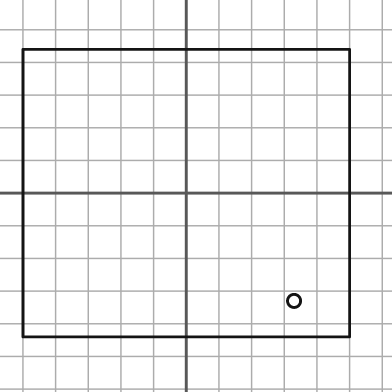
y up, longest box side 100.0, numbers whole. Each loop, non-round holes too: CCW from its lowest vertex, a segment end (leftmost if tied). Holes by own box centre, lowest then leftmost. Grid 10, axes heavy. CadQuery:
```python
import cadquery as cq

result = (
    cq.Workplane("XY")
    .moveTo(-50.0, -44.0)
    .lineTo(50.0, -44.0)
    .lineTo(50.0, 44.0)
    .lineTo(-50.0, 44.0)
    .close()
    .moveTo(33.0, -33.0)
    .circle(2.0)
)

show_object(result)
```